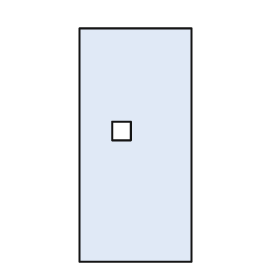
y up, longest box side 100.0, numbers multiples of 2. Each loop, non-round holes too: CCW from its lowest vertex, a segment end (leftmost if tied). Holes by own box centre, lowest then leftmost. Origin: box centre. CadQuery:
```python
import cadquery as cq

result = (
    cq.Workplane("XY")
    .moveTo(-24.0, -50.0)
    .lineTo(24.0, -50.0)
    .lineTo(24.0, 50.0)
    .lineTo(-24.0, 50.0)
    .close()
    .moveTo(-10.0, 2.0)
    .lineTo(-2.0, 2.0)
    .lineTo(-2.0, 10.0)
    .lineTo(-10.0, 10.0)
    .close()
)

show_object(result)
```